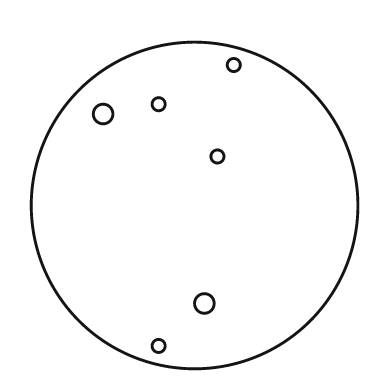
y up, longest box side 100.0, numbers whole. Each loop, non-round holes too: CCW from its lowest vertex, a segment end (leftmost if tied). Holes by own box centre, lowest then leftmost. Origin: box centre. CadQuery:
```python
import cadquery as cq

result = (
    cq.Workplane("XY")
    .moveTo(0.0, 0.0)
    .circle(50.0)
    .moveTo(-11.0, -43.0)
    .circle(2.0)
    .moveTo(3.0, -30.0)
    .circle(3.0)
    .moveTo(7.0, 15.0)
    .circle(2.0)
    .moveTo(-28.0, 28.0)
    .circle(3.0)
    .moveTo(-11.0, 31.0)
    .circle(2.0)
    .moveTo(12.0, 43.0)
    .circle(2.0)
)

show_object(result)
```